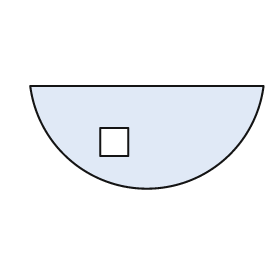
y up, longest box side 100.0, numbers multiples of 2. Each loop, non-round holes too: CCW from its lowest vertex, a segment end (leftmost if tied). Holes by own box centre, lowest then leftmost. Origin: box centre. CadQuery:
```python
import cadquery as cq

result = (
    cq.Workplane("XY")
    .moveTo(-50.0, 22.0)
    .threePointArc((0.0, -22.0), (50.0, 22.0))
    .close()
    .moveTo(-20.0, -8.0)
    .lineTo(-8.0, -8.0)
    .lineTo(-8.0, 4.0)
    .lineTo(-20.0, 4.0)
    .close()
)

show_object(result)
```